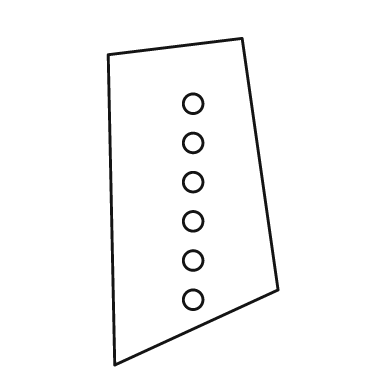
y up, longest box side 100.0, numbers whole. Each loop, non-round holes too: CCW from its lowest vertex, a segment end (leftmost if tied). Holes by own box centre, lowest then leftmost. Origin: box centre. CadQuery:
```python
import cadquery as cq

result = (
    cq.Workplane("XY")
    .moveTo(-24.0, -50.0)
    .lineTo(26.0, -27.0)
    .lineTo(15.0, 50.0)
    .lineTo(-26.0, 45.0)
    .close()
    .moveTo(0.0, -30.0)
    .circle(3.0)
    .moveTo(0.0, -18.0)
    .circle(3.0)
    .moveTo(0.0, -6.0)
    .circle(3.0)
    .moveTo(0.0, 6.0)
    .circle(3.0)
    .moveTo(0.0, 18.0)
    .circle(3.0)
    .moveTo(0.0, 30.0)
    .circle(3.0)
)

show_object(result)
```